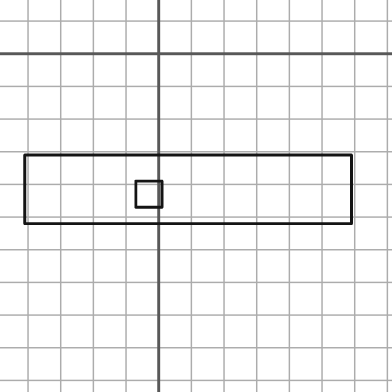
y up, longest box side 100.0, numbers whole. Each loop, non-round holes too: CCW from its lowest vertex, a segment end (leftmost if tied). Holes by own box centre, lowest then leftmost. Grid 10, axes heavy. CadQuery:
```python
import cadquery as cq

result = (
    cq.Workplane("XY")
    .moveTo(-41.0, -52.0)
    .lineTo(59.0, -52.0)
    .lineTo(59.0, -31.0)
    .lineTo(-41.0, -31.0)
    .close()
    .moveTo(-7.0, -47.0)
    .lineTo(1.0, -47.0)
    .lineTo(1.0, -39.0)
    .lineTo(-7.0, -39.0)
    .close()
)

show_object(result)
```